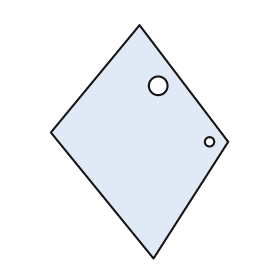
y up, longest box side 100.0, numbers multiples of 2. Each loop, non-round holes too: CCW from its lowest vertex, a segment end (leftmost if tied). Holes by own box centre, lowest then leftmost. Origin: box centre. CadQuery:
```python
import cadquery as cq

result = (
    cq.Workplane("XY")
    .moveTo(6.0, -50.0)
    .lineTo(38.0, 0.0)
    .lineTo(0.0, 50.0)
    .lineTo(-38.0, 4.0)
    .close()
    .moveTo(30.0, 0.0)
    .circle(2.0)
    .moveTo(8.0, 24.0)
    .circle(4.0)
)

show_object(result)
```